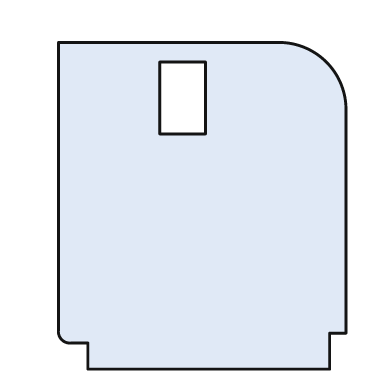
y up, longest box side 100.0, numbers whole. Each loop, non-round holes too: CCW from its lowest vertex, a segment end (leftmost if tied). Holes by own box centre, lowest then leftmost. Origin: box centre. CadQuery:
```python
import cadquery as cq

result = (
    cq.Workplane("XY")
    .moveTo(-35.0, -50.0)
    .lineTo(39.0, -50.0)
    .lineTo(39.0, -39.0)
    .lineTo(44.0, -39.0)
    .lineTo(44.0, 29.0)
    .threePointArc((38.0, 44.0), (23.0, 50.0))
    .lineTo(-44.0, 50.0)
    .lineTo(-44.0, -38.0)
    .threePointArc((-43.0, -41.0), (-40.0, -42.0))
    .lineTo(-35.0, -42.0)
    .close()
    .moveTo(-13.0, 22.0)
    .lineTo(1.0, 22.0)
    .lineTo(1.0, 44.0)
    .lineTo(-13.0, 44.0)
    .close()
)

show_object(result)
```